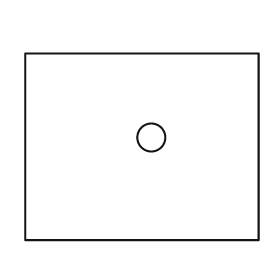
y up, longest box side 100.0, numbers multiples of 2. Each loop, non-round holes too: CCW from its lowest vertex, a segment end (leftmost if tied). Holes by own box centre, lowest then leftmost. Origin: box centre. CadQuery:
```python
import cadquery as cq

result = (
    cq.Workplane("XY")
    .moveTo(-50.0, -40.0)
    .lineTo(50.0, -40.0)
    .lineTo(50.0, 40.0)
    .lineTo(-50.0, 40.0)
    .close()
    .moveTo(4.0, 4.0)
    .circle(6.0)
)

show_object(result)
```